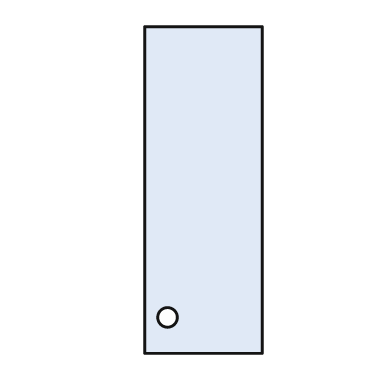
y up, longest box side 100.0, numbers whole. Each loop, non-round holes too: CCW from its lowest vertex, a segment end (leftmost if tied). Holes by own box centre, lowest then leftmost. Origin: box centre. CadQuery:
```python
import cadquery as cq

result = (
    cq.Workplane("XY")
    .moveTo(-18.0, -50.0)
    .lineTo(18.0, -50.0)
    .lineTo(18.0, 50.0)
    .lineTo(-18.0, 50.0)
    .close()
    .moveTo(-11.0, -39.0)
    .circle(3.0)
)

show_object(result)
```